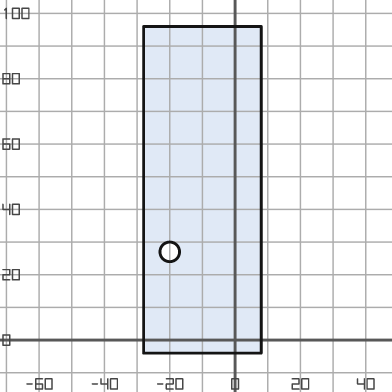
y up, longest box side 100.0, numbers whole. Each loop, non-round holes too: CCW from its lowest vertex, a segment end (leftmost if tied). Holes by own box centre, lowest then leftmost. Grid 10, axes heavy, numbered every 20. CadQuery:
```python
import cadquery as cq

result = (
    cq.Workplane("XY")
    .moveTo(-28.0, -4.0)
    .lineTo(8.0, -4.0)
    .lineTo(8.0, 96.0)
    .lineTo(-28.0, 96.0)
    .close()
    .moveTo(-20.0, 27.0)
    .circle(3.0)
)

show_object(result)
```